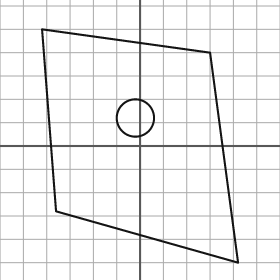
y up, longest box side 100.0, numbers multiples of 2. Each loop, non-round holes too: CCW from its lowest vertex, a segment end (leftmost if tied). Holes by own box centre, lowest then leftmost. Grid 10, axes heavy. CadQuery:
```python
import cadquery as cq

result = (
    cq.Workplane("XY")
    .moveTo(42.0, -50.0)
    .lineTo(30.0, 40.0)
    .lineTo(-42.0, 50.0)
    .lineTo(-36.0, -28.0)
    .close()
    .moveTo(-2.0, 12.0)
    .circle(8.0)
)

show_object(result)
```